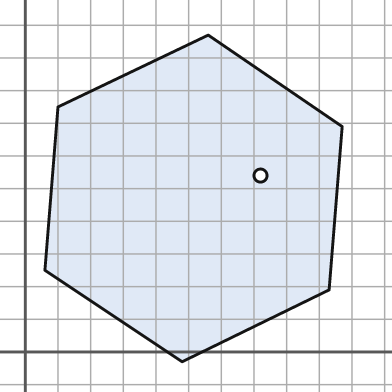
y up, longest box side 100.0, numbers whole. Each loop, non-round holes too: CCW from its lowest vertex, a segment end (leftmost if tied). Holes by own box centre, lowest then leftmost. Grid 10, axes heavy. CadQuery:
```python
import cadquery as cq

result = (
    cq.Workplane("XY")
    .moveTo(48.0, -3.0)
    .lineTo(93.0, 19.0)
    .lineTo(97.0, 69.0)
    .lineTo(56.0, 97.0)
    .lineTo(10.0, 75.0)
    .lineTo(6.0, 25.0)
    .close()
    .moveTo(72.0, 54.0)
    .circle(2.0)
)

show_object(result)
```